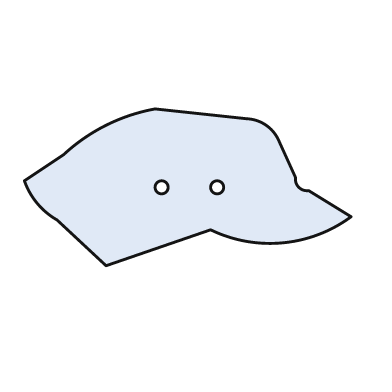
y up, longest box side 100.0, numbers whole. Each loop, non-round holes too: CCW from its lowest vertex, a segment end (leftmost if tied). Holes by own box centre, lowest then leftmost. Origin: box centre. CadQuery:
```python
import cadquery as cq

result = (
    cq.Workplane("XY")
    .moveTo(-25.0, -24.0)
    .lineTo(7.0, -13.0)
    .threePointArc((29.0, -17.0), (50.0, -9.0))
    .lineTo(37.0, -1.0)
    .threePointArc((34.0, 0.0), (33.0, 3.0))
    .lineTo(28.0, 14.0)
    .threePointArc((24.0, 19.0), (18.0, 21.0))
    .lineTo(-10.0, 24.0)
    .threePointArc((-25.0, 19.0), (-38.0, 10.0))
    .lineTo(-50.0, 2.0)
    .threePointArc((-46.0, -5.0), (-40.0, -10.0))
    .close()
    .moveTo(-8.0, 0.0)
    .circle(2.0)
    .moveTo(9.0, 0.0)
    .circle(2.0)
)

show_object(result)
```